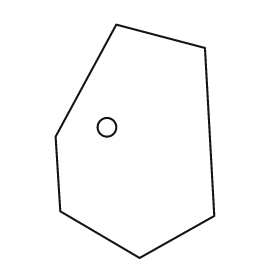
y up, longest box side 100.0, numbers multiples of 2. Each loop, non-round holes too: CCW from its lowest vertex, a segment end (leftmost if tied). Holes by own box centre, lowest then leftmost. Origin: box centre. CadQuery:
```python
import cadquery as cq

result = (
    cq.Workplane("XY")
    .moveTo(2.0, -50.0)
    .lineTo(34.0, -32.0)
    .lineTo(30.0, 40.0)
    .lineTo(-8.0, 50.0)
    .lineTo(-34.0, 2.0)
    .lineTo(-32.0, -30.0)
    .close()
    .moveTo(-12.0, 6.0)
    .circle(4.0)
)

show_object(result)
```